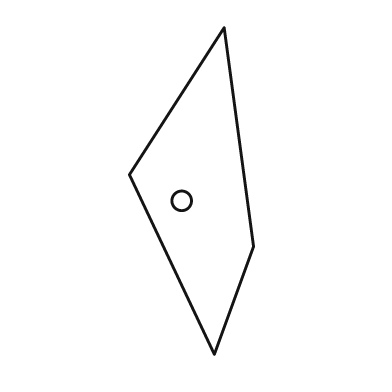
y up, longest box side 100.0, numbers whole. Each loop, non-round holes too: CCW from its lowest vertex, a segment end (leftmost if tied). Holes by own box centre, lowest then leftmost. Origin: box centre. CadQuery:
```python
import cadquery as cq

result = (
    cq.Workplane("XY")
    .moveTo(7.0, -50.0)
    .lineTo(19.0, -17.0)
    .lineTo(10.0, 50.0)
    .lineTo(-19.0, 5.0)
    .close()
    .moveTo(-3.0, -3.0)
    .circle(3.0)
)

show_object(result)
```